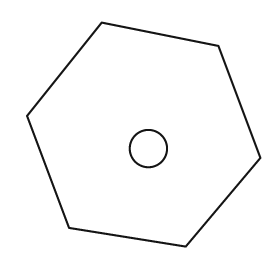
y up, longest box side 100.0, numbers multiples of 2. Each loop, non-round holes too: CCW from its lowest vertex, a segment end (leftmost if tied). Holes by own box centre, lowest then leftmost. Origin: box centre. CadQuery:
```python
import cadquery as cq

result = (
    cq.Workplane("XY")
    .moveTo(18.0, -48.0)
    .lineTo(50.0, -10.0)
    .lineTo(32.0, 38.0)
    .lineTo(-18.0, 48.0)
    .lineTo(-50.0, 8.0)
    .lineTo(-32.0, -40.0)
    .close()
    .moveTo(2.0, -6.0)
    .circle(8.0)
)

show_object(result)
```